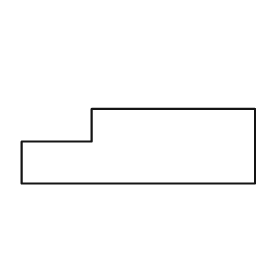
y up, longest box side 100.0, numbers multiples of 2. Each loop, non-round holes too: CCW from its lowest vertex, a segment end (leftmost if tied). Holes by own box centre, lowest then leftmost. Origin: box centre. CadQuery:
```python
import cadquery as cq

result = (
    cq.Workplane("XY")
    .moveTo(-50.0, -16.0)
    .lineTo(50.0, -16.0)
    .lineTo(50.0, 16.0)
    .lineTo(-20.0, 16.0)
    .lineTo(-20.0, 2.0)
    .lineTo(-50.0, 2.0)
    .close()
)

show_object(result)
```